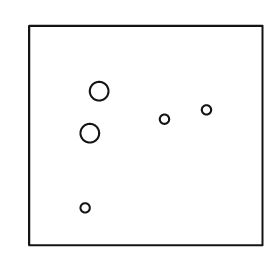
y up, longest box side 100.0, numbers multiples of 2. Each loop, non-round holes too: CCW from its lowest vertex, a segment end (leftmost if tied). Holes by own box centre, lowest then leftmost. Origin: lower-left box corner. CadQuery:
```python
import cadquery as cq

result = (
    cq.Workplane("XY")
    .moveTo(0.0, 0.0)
    .lineTo(100.0, 0.0)
    .lineTo(100.0, 94.0)
    .lineTo(0.0, 94.0)
    .close()
    .moveTo(24.0, 16.0)
    .circle(2.0)
    .moveTo(26.0, 48.0)
    .circle(4.0)
    .moveTo(58.0, 54.0)
    .circle(2.0)
    .moveTo(76.0, 58.0)
    .circle(2.0)
    .moveTo(30.0, 66.0)
    .circle(4.0)
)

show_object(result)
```